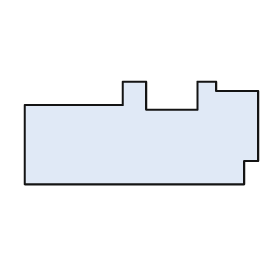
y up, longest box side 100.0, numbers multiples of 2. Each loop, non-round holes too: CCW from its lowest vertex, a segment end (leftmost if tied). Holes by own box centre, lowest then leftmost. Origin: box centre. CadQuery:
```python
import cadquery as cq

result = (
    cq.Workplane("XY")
    .moveTo(-50.0, -22.0)
    .lineTo(44.0, -22.0)
    .lineTo(44.0, -12.0)
    .lineTo(50.0, -12.0)
    .lineTo(50.0, 18.0)
    .lineTo(32.0, 18.0)
    .lineTo(32.0, 22.0)
    .lineTo(24.0, 22.0)
    .lineTo(24.0, 10.0)
    .lineTo(2.0, 10.0)
    .lineTo(2.0, 22.0)
    .lineTo(-8.0, 22.0)
    .lineTo(-8.0, 12.0)
    .lineTo(-50.0, 12.0)
    .close()
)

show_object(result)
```